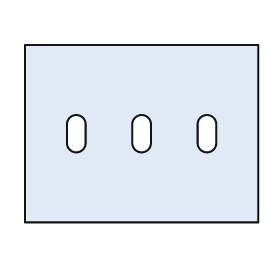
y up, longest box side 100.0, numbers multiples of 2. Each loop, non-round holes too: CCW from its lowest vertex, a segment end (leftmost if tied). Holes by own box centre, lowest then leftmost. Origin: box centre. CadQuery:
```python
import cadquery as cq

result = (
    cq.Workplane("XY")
    .moveTo(-50.0, -38.0)
    .lineTo(50.0, -38.0)
    .lineTo(50.0, 38.0)
    .lineTo(-50.0, 38.0)
    .close()
    .moveTo(-32.0, -4.0)
    .threePointArc((-28.0, -8.0), (-24.0, -4.0))
    .lineTo(-24.0, 4.0)
    .threePointArc((-28.0, 8.0), (-32.0, 4.0))
    .close()
    .moveTo(-4.0, -4.0)
    .threePointArc((0.0, -8.0), (4.0, -4.0))
    .lineTo(4.0, 4.0)
    .threePointArc((0.0, 8.0), (-4.0, 4.0))
    .close()
    .moveTo(24.0, -4.0)
    .threePointArc((28.0, -8.0), (32.0, -4.0))
    .lineTo(32.0, 4.0)
    .threePointArc((28.0, 8.0), (24.0, 4.0))
    .close()
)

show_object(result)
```